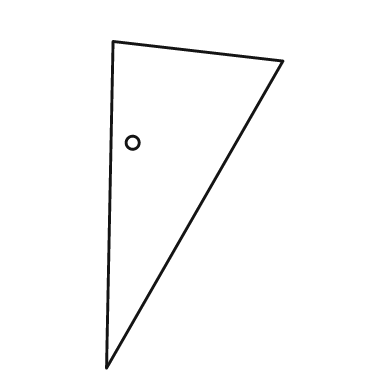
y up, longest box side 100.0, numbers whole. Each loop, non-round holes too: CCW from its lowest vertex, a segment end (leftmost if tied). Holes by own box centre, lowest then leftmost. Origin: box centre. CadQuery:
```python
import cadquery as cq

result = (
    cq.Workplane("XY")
    .moveTo(-27.0, -50.0)
    .lineTo(27.0, 44.0)
    .lineTo(-25.0, 50.0)
    .close()
    .moveTo(-19.0, 19.0)
    .circle(2.0)
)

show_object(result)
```